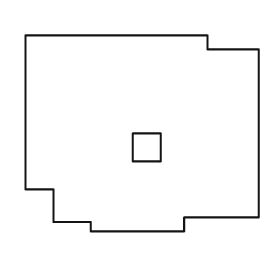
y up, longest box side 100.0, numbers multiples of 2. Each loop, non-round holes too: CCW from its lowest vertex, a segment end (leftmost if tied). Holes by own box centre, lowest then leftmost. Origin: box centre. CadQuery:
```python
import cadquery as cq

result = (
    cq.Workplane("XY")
    .moveTo(-22.0, -42.0)
    .lineTo(18.0, -42.0)
    .lineTo(18.0, -36.0)
    .lineTo(50.0, -36.0)
    .lineTo(50.0, 36.0)
    .lineTo(28.0, 36.0)
    .lineTo(28.0, 42.0)
    .lineTo(-50.0, 42.0)
    .lineTo(-50.0, -24.0)
    .lineTo(-38.0, -24.0)
    .lineTo(-38.0, -38.0)
    .lineTo(-22.0, -38.0)
    .close()
    .moveTo(-4.0, -12.0)
    .lineTo(8.0, -12.0)
    .lineTo(8.0, 0.0)
    .lineTo(-4.0, 0.0)
    .close()
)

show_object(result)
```